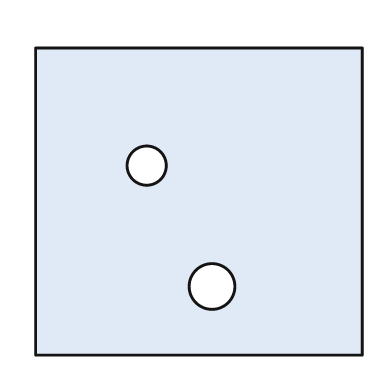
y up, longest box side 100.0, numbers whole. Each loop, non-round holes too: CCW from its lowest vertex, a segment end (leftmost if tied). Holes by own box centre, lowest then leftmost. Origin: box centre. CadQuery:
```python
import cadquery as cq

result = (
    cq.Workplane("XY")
    .moveTo(-50.0, -47.0)
    .lineTo(50.0, -47.0)
    .lineTo(50.0, 47.0)
    .lineTo(-50.0, 47.0)
    .close()
    .moveTo(4.0, -26.0)
    .circle(7.0)
    .moveTo(-16.0, 11.0)
    .circle(6.0)
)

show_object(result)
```